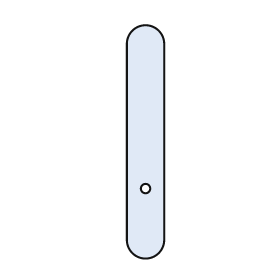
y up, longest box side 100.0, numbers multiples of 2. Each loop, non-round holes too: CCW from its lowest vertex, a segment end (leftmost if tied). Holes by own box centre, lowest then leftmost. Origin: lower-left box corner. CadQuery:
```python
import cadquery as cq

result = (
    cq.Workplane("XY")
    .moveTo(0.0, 8.0)
    .threePointArc((8.0, 0.0), (16.0, 8.0))
    .lineTo(16.0, 92.0)
    .threePointArc((8.0, 100.0), (0.0, 92.0))
    .close()
    .moveTo(8.0, 30.0)
    .circle(2.0)
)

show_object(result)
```